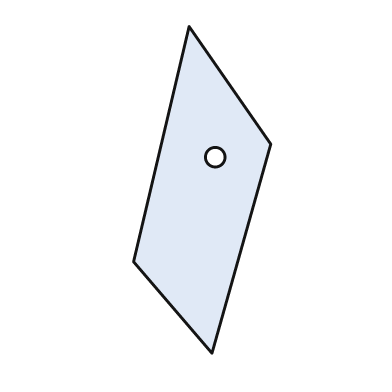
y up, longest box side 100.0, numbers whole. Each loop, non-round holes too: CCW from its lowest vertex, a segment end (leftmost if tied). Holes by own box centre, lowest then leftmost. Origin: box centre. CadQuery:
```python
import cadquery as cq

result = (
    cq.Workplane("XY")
    .moveTo(3.0, -50.0)
    .lineTo(21.0, 14.0)
    .lineTo(-4.0, 50.0)
    .lineTo(-21.0, -22.0)
    .close()
    .moveTo(4.0, 10.0)
    .circle(3.0)
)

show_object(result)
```